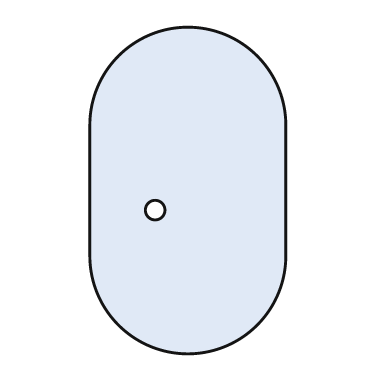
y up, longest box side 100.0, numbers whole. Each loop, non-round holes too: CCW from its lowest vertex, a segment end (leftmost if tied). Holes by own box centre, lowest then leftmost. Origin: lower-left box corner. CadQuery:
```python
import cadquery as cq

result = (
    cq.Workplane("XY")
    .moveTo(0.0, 30.0)
    .threePointArc((30.0, 0.0), (60.0, 30.0))
    .lineTo(60.0, 70.0)
    .threePointArc((30.0, 100.0), (0.0, 70.0))
    .close()
    .moveTo(20.0, 44.0)
    .circle(3.0)
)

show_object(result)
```